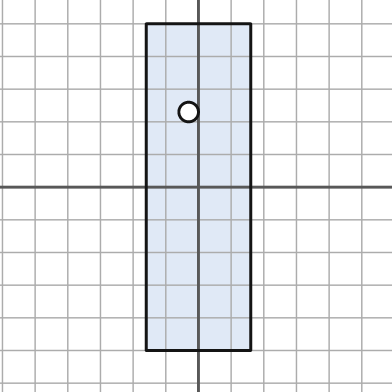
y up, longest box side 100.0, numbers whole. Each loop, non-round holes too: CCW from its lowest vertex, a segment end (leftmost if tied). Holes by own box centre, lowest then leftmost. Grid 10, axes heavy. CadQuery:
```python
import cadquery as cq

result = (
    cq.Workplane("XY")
    .moveTo(-16.0, -50.0)
    .lineTo(16.0, -50.0)
    .lineTo(16.0, 50.0)
    .lineTo(-16.0, 50.0)
    .close()
    .moveTo(-3.0, 23.0)
    .circle(3.0)
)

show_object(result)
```